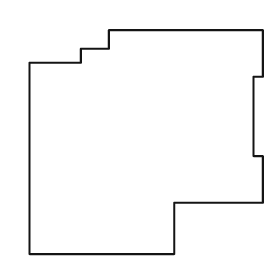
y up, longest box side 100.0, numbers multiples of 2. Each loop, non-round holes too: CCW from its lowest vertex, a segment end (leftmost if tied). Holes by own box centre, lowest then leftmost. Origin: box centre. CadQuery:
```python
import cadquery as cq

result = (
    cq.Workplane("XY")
    .moveTo(-50.0, -48.0)
    .lineTo(12.0, -48.0)
    .lineTo(12.0, -26.0)
    .lineTo(50.0, -26.0)
    .lineTo(50.0, -6.0)
    .lineTo(46.0, -6.0)
    .lineTo(46.0, 28.0)
    .lineTo(50.0, 28.0)
    .lineTo(50.0, 48.0)
    .lineTo(-16.0, 48.0)
    .lineTo(-16.0, 40.0)
    .lineTo(-28.0, 40.0)
    .lineTo(-28.0, 34.0)
    .lineTo(-50.0, 34.0)
    .close()
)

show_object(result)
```